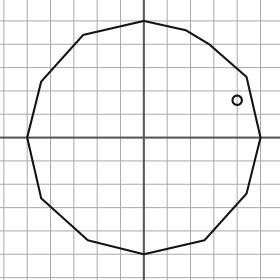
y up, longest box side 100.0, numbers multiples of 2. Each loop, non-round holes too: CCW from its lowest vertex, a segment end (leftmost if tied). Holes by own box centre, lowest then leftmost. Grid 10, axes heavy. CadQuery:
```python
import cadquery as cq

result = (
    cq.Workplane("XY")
    .moveTo(0.0, -50.0)
    .lineTo(26.0, -44.0)
    .lineTo(44.0, -24.0)
    .lineTo(50.0, 0.0)
    .lineTo(44.0, 26.0)
    .lineTo(28.0, 40.0)
    .lineTo(18.0, 46.0)
    .lineTo(0.0, 50.0)
    .lineTo(-26.0, 44.0)
    .lineTo(-44.0, 24.0)
    .lineTo(-50.0, 0.0)
    .lineTo(-44.0, -26.0)
    .lineTo(-24.0, -44.0)
    .close()
    .moveTo(40.0, 16.0)
    .circle(2.0)
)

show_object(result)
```